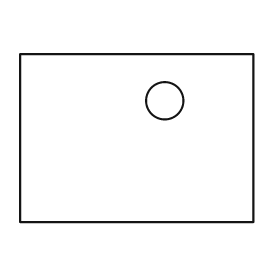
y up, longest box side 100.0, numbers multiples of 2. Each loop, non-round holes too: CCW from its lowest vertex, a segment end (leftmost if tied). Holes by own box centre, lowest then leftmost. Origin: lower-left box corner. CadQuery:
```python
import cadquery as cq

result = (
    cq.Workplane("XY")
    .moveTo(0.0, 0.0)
    .lineTo(100.0, 0.0)
    .lineTo(100.0, 72.0)
    .lineTo(0.0, 72.0)
    .close()
    .moveTo(62.0, 52.0)
    .circle(8.0)
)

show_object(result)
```